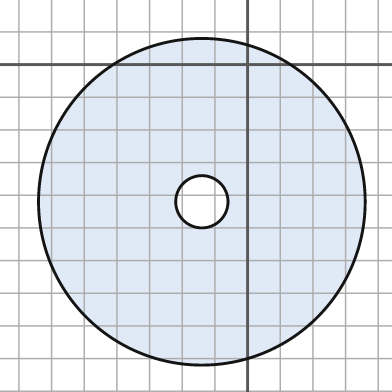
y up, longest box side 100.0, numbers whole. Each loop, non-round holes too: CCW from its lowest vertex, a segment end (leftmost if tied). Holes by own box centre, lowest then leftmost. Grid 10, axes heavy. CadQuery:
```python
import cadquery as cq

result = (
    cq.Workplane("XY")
    .moveTo(-14.0, -42.0)
    .circle(50.0)
    .moveTo(-14.0, -42.0)
    .circle(8.0)
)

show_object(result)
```